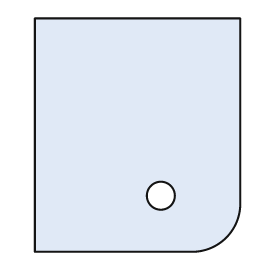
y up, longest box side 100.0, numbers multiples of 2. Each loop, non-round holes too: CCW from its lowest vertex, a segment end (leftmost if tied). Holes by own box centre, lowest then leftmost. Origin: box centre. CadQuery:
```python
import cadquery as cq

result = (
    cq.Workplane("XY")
    .moveTo(-44.0, -50.0)
    .lineTo(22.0, -50.0)
    .threePointArc((38.0, -44.0), (44.0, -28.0))
    .lineTo(44.0, 50.0)
    .lineTo(-44.0, 50.0)
    .close()
    .moveTo(10.0, -26.0)
    .circle(6.0)
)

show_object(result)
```